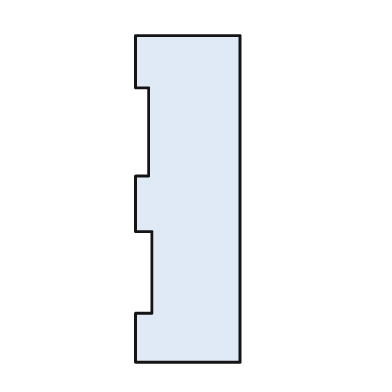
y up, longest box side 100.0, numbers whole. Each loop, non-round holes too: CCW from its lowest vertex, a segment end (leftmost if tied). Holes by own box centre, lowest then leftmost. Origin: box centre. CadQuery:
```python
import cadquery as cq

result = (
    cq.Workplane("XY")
    .moveTo(-16.0, -50.0)
    .lineTo(16.0, -50.0)
    .lineTo(16.0, 50.0)
    .lineTo(-16.0, 50.0)
    .lineTo(-16.0, 34.0)
    .lineTo(-12.0, 34.0)
    .lineTo(-12.0, 7.0)
    .lineTo(-16.0, 7.0)
    .lineTo(-16.0, -10.0)
    .lineTo(-11.0, -10.0)
    .lineTo(-11.0, -35.0)
    .lineTo(-16.0, -35.0)
    .close()
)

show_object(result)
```